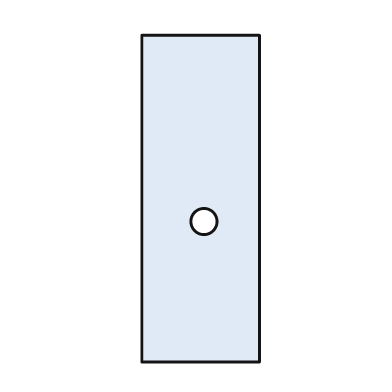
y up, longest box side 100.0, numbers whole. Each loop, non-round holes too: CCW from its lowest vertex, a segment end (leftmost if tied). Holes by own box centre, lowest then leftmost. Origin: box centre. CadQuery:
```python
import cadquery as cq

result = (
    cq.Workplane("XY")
    .moveTo(-18.0, -50.0)
    .lineTo(18.0, -50.0)
    .lineTo(18.0, 50.0)
    .lineTo(-18.0, 50.0)
    .close()
    .moveTo(1.0, -7.0)
    .circle(4.0)
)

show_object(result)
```